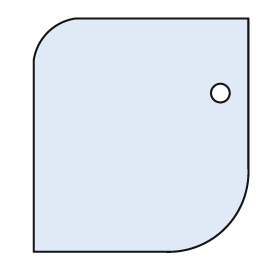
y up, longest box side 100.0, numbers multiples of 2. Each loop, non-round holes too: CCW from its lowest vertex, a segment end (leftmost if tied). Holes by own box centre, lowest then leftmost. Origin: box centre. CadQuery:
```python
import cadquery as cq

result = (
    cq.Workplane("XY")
    .moveTo(-46.0, -50.0)
    .lineTo(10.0, -50.0)
    .threePointArc((36.0, -40.0), (46.0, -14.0))
    .lineTo(46.0, 50.0)
    .lineTo(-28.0, 50.0)
    .threePointArc((-40.0, 44.0), (-46.0, 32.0))
    .close()
    .moveTo(34.0, 18.0)
    .circle(4.0)
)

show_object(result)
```